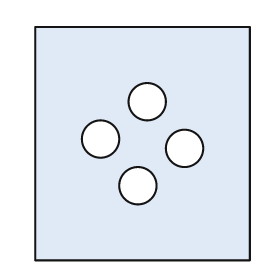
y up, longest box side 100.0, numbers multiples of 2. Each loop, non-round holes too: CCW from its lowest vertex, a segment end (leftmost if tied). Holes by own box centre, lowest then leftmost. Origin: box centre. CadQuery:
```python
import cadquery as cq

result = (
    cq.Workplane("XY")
    .moveTo(-46.0, -50.0)
    .lineTo(46.0, -50.0)
    .lineTo(46.0, 50.0)
    .lineTo(-46.0, 50.0)
    .close()
    .moveTo(-2.0, -18.0)
    .circle(8.0)
    .moveTo(18.0, -2.0)
    .circle(8.0)
    .moveTo(-18.0, 2.0)
    .circle(8.0)
    .moveTo(2.0, 18.0)
    .circle(8.0)
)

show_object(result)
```